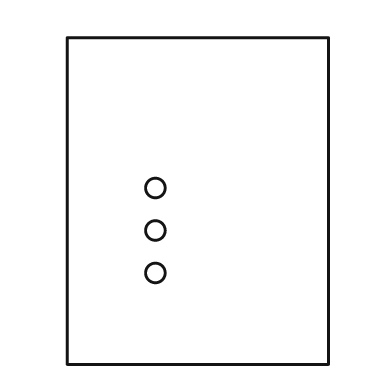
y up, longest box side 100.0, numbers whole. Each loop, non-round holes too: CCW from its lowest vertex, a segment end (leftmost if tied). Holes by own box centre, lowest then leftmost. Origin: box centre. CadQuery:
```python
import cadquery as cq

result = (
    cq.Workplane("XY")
    .moveTo(-40.0, -50.0)
    .lineTo(40.0, -50.0)
    .lineTo(40.0, 50.0)
    .lineTo(-40.0, 50.0)
    .close()
    .moveTo(-13.0, -22.0)
    .circle(3.0)
    .moveTo(-13.0, -9.0)
    .circle(3.0)
    .moveTo(-13.0, 4.0)
    .circle(3.0)
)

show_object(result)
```